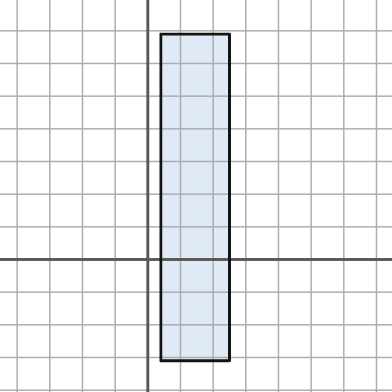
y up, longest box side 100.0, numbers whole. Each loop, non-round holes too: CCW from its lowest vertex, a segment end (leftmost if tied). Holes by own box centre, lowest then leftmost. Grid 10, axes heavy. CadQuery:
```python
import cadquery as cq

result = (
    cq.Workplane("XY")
    .moveTo(4.0, -31.0)
    .lineTo(25.0, -31.0)
    .lineTo(25.0, 69.0)
    .lineTo(4.0, 69.0)
    .close()
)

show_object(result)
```